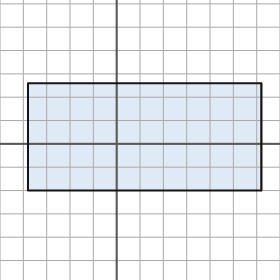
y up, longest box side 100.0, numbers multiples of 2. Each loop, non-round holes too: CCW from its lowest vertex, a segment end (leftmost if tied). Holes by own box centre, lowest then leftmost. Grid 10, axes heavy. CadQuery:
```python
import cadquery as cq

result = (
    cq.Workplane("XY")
    .moveTo(-38.0, -20.0)
    .lineTo(62.0, -20.0)
    .lineTo(62.0, 26.0)
    .lineTo(-38.0, 26.0)
    .close()
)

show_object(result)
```